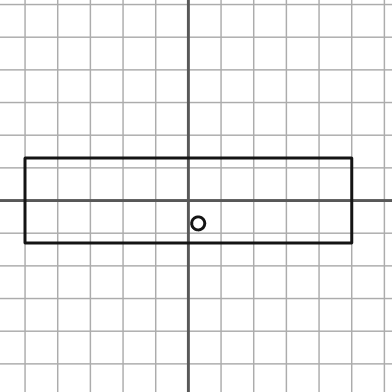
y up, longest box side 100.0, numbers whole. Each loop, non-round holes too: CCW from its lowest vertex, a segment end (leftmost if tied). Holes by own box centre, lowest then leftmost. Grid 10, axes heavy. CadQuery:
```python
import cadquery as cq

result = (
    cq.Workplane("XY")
    .moveTo(-50.0, -13.0)
    .lineTo(50.0, -13.0)
    .lineTo(50.0, 13.0)
    .lineTo(-50.0, 13.0)
    .close()
    .moveTo(3.0, -7.0)
    .circle(2.0)
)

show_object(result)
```